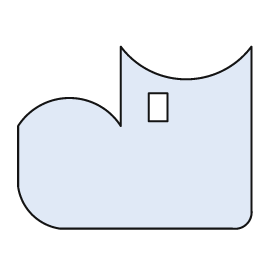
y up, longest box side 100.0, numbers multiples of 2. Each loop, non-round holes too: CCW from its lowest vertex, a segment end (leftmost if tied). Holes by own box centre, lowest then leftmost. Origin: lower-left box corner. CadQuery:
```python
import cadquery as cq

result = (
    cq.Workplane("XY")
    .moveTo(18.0, 0.0)
    .lineTo(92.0, 0.0)
    .threePointArc((98.0, 2.0), (100.0, 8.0))
    .lineTo(100.0, 78.0)
    .threePointArc((72.0, 64.0), (44.0, 78.0))
    .lineTo(44.0, 44.0)
    .threePointArc((22.0, 56.0), (0.0, 44.0))
    .lineTo(0.0, 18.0)
    .threePointArc((6.0, 6.0), (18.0, 0.0))
    .close()
    .moveTo(56.0, 46.0)
    .lineTo(64.0, 46.0)
    .lineTo(64.0, 58.0)
    .lineTo(56.0, 58.0)
    .close()
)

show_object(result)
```